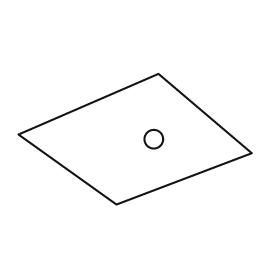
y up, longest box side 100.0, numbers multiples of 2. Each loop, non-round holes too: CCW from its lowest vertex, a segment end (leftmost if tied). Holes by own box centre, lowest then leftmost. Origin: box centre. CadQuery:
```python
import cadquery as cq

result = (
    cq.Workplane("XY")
    .moveTo(-8.0, -28.0)
    .lineTo(50.0, -6.0)
    .lineTo(10.0, 28.0)
    .lineTo(-50.0, 2.0)
    .close()
    .moveTo(8.0, 0.0)
    .circle(4.0)
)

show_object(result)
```